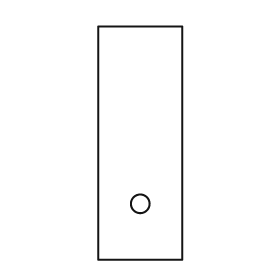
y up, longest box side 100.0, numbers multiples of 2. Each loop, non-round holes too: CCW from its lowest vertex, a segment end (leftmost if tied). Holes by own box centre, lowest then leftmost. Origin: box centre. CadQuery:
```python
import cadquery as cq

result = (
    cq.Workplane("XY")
    .moveTo(-18.0, -50.0)
    .lineTo(18.0, -50.0)
    .lineTo(18.0, 50.0)
    .lineTo(-18.0, 50.0)
    .close()
    .moveTo(0.0, -26.0)
    .circle(4.0)
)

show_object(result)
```